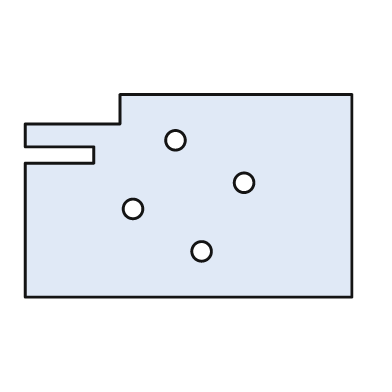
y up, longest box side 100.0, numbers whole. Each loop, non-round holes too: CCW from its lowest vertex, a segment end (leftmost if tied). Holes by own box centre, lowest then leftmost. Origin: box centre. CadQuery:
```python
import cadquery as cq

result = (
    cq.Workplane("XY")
    .moveTo(-50.0, -31.0)
    .lineTo(50.0, -31.0)
    .lineTo(50.0, 31.0)
    .lineTo(-21.0, 31.0)
    .lineTo(-21.0, 22.0)
    .lineTo(-50.0, 22.0)
    .lineTo(-50.0, 15.0)
    .lineTo(-29.0, 15.0)
    .lineTo(-29.0, 10.0)
    .lineTo(-50.0, 10.0)
    .close()
    .moveTo(4.0, -17.0)
    .circle(3.0)
    .moveTo(-17.0, -4.0)
    .circle(3.0)
    .moveTo(17.0, 4.0)
    .circle(3.0)
    .moveTo(-4.0, 17.0)
    .circle(3.0)
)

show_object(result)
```